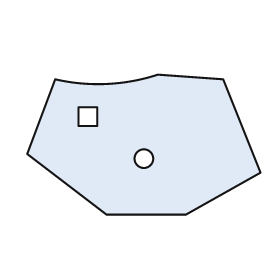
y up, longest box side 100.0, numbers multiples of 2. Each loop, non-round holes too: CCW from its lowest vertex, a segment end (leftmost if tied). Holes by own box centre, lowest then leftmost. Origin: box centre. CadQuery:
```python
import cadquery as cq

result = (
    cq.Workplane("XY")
    .moveTo(-16.0, -30.0)
    .lineTo(18.0, -30.0)
    .lineTo(50.0, -12.0)
    .lineTo(34.0, 28.0)
    .lineTo(6.0, 30.0)
    .threePointArc((-16.0, 26.0), (-38.0, 28.0))
    .lineTo(-50.0, -4.0)
    .close()
    .moveTo(0.0, -6.0)
    .circle(4.0)
    .moveTo(-28.0, 8.0)
    .lineTo(-20.0, 8.0)
    .lineTo(-20.0, 16.0)
    .lineTo(-28.0, 16.0)
    .close()
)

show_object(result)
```